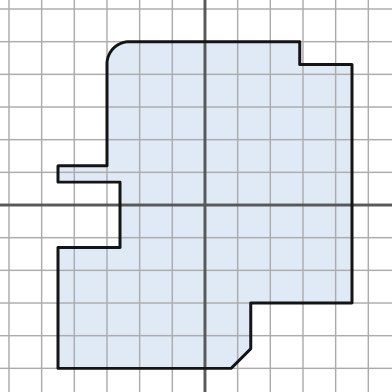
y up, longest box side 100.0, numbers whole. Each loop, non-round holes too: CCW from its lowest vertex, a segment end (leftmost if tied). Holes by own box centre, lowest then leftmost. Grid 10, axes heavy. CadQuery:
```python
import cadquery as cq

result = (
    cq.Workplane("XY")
    .moveTo(-45.0, -50.0)
    .lineTo(8.0, -50.0)
    .lineTo(14.0, -44.0)
    .lineTo(14.0, -30.0)
    .lineTo(45.0, -30.0)
    .lineTo(45.0, 43.0)
    .lineTo(29.0, 43.0)
    .lineTo(29.0, 50.0)
    .lineTo(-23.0, 50.0)
    .threePointArc((-28.0, 48.0), (-30.0, 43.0))
    .lineTo(-30.0, 12.0)
    .lineTo(-45.0, 12.0)
    .lineTo(-45.0, 7.0)
    .lineTo(-26.0, 7.0)
    .lineTo(-26.0, -13.0)
    .lineTo(-45.0, -13.0)
    .close()
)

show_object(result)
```